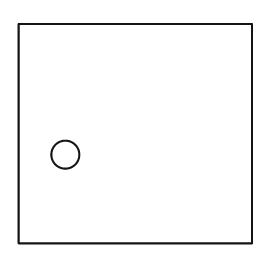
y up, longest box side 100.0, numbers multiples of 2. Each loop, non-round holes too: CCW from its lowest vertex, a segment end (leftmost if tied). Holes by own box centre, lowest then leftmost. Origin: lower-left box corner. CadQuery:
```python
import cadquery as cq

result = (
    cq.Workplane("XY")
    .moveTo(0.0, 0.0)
    .lineTo(100.0, 0.0)
    .lineTo(100.0, 94.0)
    .lineTo(0.0, 94.0)
    .close()
    .moveTo(20.0, 38.0)
    .circle(6.0)
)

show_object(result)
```